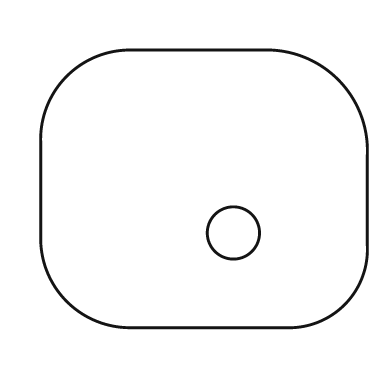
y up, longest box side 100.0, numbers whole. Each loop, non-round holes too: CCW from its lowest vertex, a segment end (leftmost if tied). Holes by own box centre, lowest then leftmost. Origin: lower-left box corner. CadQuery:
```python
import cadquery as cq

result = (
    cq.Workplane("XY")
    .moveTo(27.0, 0.0)
    .lineTo(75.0, 0.0)
    .threePointArc((93.0, 7.0), (100.0, 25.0))
    .lineTo(100.0, 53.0)
    .threePointArc((91.0, 76.0), (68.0, 85.0))
    .lineTo(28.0, 85.0)
    .threePointArc((8.0, 77.0), (0.0, 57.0))
    .lineTo(0.0, 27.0)
    .threePointArc((8.0, 8.0), (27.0, 0.0))
    .close()
    .moveTo(59.0, 29.0)
    .circle(8.0)
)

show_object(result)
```